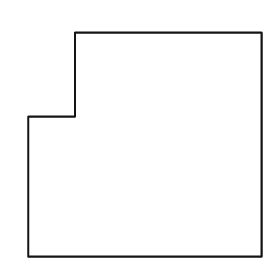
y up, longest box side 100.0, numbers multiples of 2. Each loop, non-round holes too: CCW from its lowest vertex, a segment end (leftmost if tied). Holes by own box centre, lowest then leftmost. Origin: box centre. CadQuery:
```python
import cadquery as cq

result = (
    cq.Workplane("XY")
    .moveTo(-50.0, -48.0)
    .lineTo(50.0, -48.0)
    .lineTo(50.0, 48.0)
    .lineTo(-30.0, 48.0)
    .lineTo(-30.0, 12.0)
    .lineTo(-50.0, 12.0)
    .close()
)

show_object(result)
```